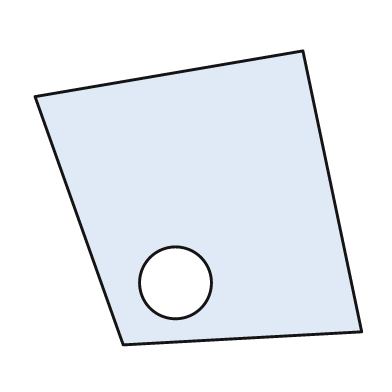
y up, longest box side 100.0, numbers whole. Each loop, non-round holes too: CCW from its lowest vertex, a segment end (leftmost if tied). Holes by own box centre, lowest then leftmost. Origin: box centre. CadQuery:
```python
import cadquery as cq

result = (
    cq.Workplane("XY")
    .moveTo(-23.0, -45.0)
    .lineTo(50.0, -41.0)
    .lineTo(32.0, 45.0)
    .lineTo(-50.0, 31.0)
    .close()
    .moveTo(-7.0, -26.0)
    .circle(11.0)
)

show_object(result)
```